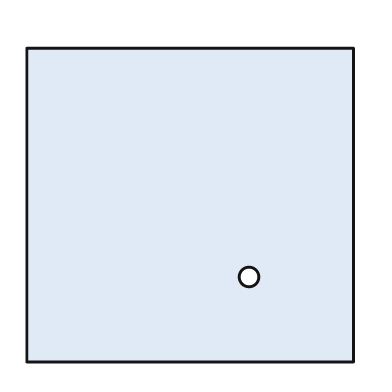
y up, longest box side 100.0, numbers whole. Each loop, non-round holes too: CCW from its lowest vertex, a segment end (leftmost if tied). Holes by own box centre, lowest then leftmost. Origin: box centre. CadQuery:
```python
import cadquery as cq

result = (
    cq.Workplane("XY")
    .moveTo(-50.0, -48.0)
    .lineTo(50.0, -48.0)
    .lineTo(50.0, 48.0)
    .lineTo(-50.0, 48.0)
    .close()
    .moveTo(18.0, -22.0)
    .circle(3.0)
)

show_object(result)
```